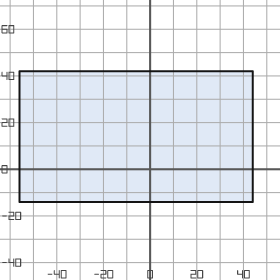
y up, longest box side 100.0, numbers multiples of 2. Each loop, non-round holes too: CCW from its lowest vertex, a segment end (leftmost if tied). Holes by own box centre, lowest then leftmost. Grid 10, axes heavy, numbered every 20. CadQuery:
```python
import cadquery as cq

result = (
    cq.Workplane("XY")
    .moveTo(-56.0, -14.0)
    .lineTo(44.0, -14.0)
    .lineTo(44.0, 42.0)
    .lineTo(-56.0, 42.0)
    .close()
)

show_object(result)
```